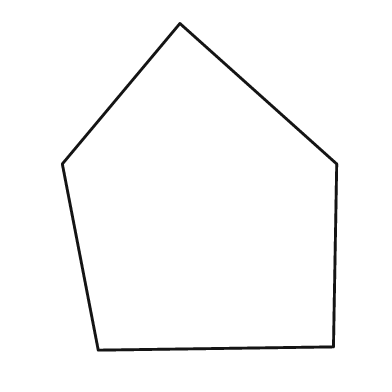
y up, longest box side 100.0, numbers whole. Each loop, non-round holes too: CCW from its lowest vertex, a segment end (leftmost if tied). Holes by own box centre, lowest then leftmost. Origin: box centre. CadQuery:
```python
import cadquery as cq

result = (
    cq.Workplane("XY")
    .moveTo(-31.0, -50.0)
    .lineTo(41.0, -49.0)
    .lineTo(42.0, 7.0)
    .lineTo(-6.0, 50.0)
    .lineTo(-42.0, 7.0)
    .close()
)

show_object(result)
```